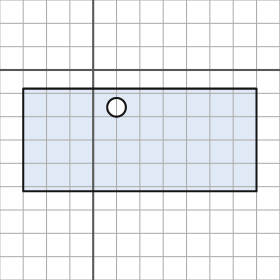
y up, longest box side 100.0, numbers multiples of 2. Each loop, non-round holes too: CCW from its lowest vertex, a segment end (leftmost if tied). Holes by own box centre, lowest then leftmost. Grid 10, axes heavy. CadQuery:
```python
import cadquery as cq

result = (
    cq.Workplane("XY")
    .moveTo(-30.0, -52.0)
    .lineTo(70.0, -52.0)
    .lineTo(70.0, -8.0)
    .lineTo(-30.0, -8.0)
    .close()
    .moveTo(10.0, -16.0)
    .circle(4.0)
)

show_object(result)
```